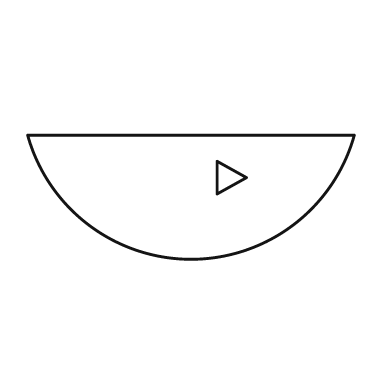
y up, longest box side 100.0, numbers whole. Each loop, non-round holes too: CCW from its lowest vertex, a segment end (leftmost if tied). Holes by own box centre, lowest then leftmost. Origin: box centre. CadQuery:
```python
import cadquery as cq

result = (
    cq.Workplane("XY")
    .moveTo(-50.0, 19.0)
    .threePointArc((0.0, -19.0), (50.0, 19.0))
    .close()
    .moveTo(8.0, 1.0)
    .lineTo(17.0, 6.0)
    .lineTo(8.0, 11.0)
    .close()
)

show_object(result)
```